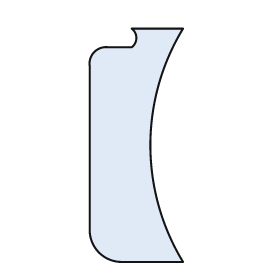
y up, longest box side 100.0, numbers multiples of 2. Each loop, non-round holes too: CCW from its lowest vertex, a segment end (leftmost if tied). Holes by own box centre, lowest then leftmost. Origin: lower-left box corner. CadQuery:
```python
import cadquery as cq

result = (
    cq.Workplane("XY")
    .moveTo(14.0, 0.0)
    .lineTo(40.0, 0.0)
    .threePointArc((26.0, 50.0), (40.0, 100.0))
    .lineTo(18.0, 100.0)
    .threePointArc((20.0, 96.0), (18.0, 92.0))
    .lineTo(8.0, 92.0)
    .threePointArc((2.0, 90.0), (0.0, 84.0))
    .lineTo(0.0, 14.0)
    .threePointArc((4.0, 4.0), (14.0, 0.0))
    .close()
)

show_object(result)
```